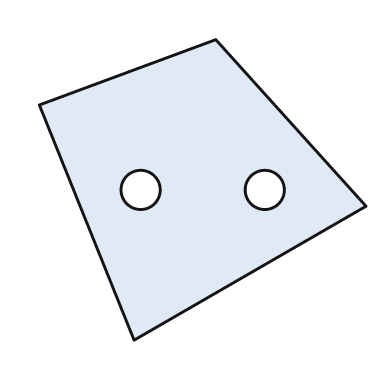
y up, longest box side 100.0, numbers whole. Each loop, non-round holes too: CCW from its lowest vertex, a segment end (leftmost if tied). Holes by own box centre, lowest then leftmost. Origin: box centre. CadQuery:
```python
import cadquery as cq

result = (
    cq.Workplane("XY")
    .moveTo(-21.0, -46.0)
    .lineTo(50.0, -5.0)
    .lineTo(4.0, 46.0)
    .lineTo(-50.0, 26.0)
    .close()
    .moveTo(-19.0, 0.0)
    .circle(6.0)
    .moveTo(19.0, 0.0)
    .circle(6.0)
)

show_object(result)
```